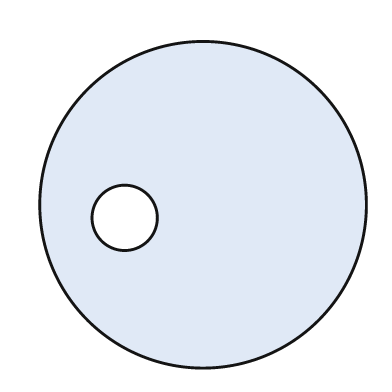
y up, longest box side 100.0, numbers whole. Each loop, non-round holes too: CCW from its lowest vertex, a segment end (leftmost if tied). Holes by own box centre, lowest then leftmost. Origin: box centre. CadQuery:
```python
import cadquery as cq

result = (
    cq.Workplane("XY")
    .moveTo(0.0, 0.0)
    .circle(50.0)
    .moveTo(-24.0, -4.0)
    .circle(10.0)
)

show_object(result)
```